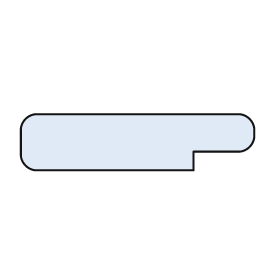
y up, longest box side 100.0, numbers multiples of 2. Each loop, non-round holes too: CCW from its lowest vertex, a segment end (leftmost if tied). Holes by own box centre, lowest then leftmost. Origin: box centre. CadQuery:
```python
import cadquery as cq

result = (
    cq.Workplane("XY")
    .moveTo(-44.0, -12.0)
    .lineTo(24.0, -12.0)
    .lineTo(24.0, -4.0)
    .lineTo(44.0, -4.0)
    .threePointArc((48.0, -2.0), (50.0, 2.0))
    .lineTo(50.0, 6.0)
    .threePointArc((48.0, 10.0), (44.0, 12.0))
    .lineTo(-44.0, 12.0)
    .threePointArc((-48.0, 10.0), (-50.0, 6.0))
    .lineTo(-50.0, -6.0)
    .threePointArc((-48.0, -10.0), (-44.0, -12.0))
    .close()
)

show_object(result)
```